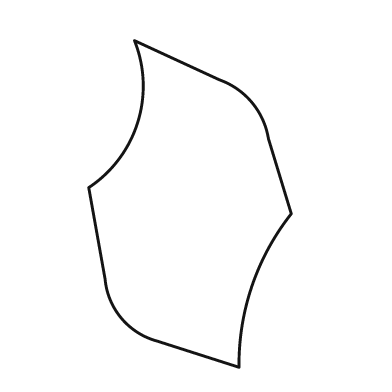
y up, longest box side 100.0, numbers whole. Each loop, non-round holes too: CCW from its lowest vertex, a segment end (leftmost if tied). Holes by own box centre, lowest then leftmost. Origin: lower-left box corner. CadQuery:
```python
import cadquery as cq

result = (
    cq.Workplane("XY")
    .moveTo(46.0, 0.0)
    .threePointArc((50.0, 25.0), (62.0, 47.0))
    .lineTo(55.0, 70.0)
    .threePointArc((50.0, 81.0), (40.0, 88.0))
    .lineTo(14.0, 100.0)
    .threePointArc((15.0, 75.0), (0.0, 55.0))
    .lineTo(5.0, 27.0)
    .threePointArc((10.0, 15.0), (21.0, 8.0))
    .close()
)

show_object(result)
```